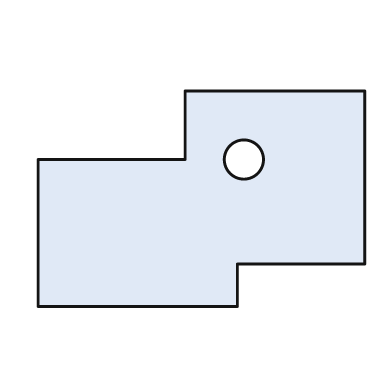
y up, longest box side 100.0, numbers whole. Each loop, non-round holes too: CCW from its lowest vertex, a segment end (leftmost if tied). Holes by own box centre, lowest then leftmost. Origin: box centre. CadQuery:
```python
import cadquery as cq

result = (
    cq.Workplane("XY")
    .moveTo(-50.0, -33.0)
    .lineTo(11.0, -33.0)
    .lineTo(11.0, -20.0)
    .lineTo(50.0, -20.0)
    .lineTo(50.0, 33.0)
    .lineTo(-5.0, 33.0)
    .lineTo(-5.0, 12.0)
    .lineTo(-50.0, 12.0)
    .close()
    .moveTo(13.0, 12.0)
    .circle(6.0)
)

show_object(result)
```